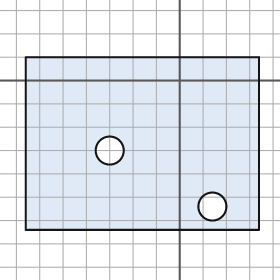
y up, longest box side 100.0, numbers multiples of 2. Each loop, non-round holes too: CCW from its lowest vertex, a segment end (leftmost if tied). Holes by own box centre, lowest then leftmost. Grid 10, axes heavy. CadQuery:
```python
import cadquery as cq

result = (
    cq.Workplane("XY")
    .moveTo(-66.0, -64.0)
    .lineTo(34.0, -64.0)
    .lineTo(34.0, 10.0)
    .lineTo(-66.0, 10.0)
    .close()
    .moveTo(14.0, -54.0)
    .circle(6.0)
    .moveTo(-30.0, -30.0)
    .circle(6.0)
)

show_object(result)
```